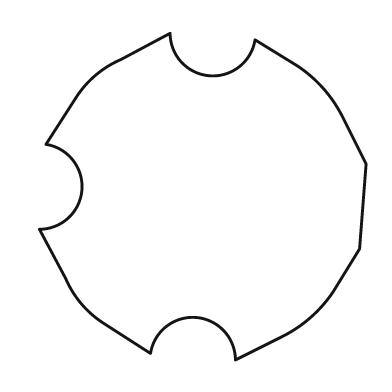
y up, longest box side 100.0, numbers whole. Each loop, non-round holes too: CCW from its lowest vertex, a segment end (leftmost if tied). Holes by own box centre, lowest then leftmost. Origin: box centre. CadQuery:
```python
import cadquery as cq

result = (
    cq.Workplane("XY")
    .moveTo(10.0, -50.0)
    .lineTo(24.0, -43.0)
    .threePointArc((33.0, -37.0), (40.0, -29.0))
    .lineTo(48.0, -16.0)
    .lineTo(50.0, 10.0)
    .lineTo(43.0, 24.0)
    .threePointArc((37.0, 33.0), (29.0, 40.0))
    .lineTo(16.0, 48.0)
    .threePointArc((2.0, 37.0), (-10.0, 50.0))
    .lineTo(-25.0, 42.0)
    .threePointArc((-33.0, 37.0), (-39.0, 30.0))
    .lineTo(-48.0, 16.0)
    .threePointArc((-37.0, 2.0), (-50.0, -10.0))
    .lineTo(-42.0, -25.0)
    .threePointArc((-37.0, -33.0), (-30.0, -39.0))
    .lineTo(-16.0, -48.0)
    .threePointArc((-2.0, -37.0), (10.0, -50.0))
    .close()
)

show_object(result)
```